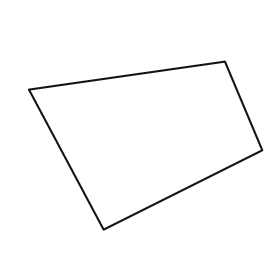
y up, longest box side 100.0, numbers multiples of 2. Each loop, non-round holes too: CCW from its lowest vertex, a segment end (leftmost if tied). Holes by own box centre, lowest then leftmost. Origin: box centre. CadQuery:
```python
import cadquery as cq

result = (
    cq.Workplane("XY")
    .moveTo(-18.0, -36.0)
    .lineTo(50.0, -2.0)
    .lineTo(34.0, 36.0)
    .lineTo(-50.0, 24.0)
    .close()
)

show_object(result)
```